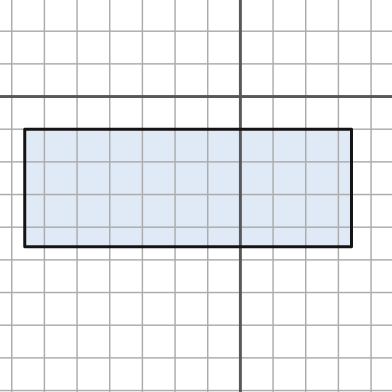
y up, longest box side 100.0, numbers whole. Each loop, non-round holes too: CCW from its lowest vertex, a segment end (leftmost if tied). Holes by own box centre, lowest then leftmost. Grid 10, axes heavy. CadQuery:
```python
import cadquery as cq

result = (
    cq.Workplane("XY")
    .moveTo(-66.0, -46.0)
    .lineTo(34.0, -46.0)
    .lineTo(34.0, -10.0)
    .lineTo(-66.0, -10.0)
    .close()
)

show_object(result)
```